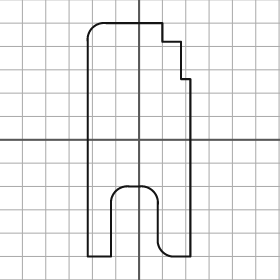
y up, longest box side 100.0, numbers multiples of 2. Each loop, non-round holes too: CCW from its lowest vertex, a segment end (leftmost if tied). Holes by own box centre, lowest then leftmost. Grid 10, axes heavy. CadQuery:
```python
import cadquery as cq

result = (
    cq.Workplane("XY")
    .moveTo(-22.0, -50.0)
    .lineTo(-12.0, -50.0)
    .lineTo(-12.0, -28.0)
    .threePointArc((-10.0, -22.0), (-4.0, -20.0))
    .lineTo(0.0, -20.0)
    .threePointArc((6.0, -22.0), (8.0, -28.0))
    .lineTo(8.0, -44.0)
    .threePointArc((10.0, -48.0), (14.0, -50.0))
    .lineTo(22.0, -50.0)
    .lineTo(22.0, 26.0)
    .lineTo(18.0, 26.0)
    .lineTo(18.0, 42.0)
    .lineTo(10.0, 42.0)
    .lineTo(10.0, 50.0)
    .lineTo(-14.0, 50.0)
    .threePointArc((-20.0, 48.0), (-22.0, 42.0))
    .close()
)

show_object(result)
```